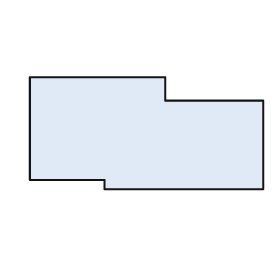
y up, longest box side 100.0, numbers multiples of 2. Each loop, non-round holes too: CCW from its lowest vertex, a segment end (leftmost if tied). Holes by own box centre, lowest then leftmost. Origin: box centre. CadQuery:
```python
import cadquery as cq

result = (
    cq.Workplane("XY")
    .moveTo(-18.0, -24.0)
    .lineTo(50.0, -24.0)
    .lineTo(50.0, 14.0)
    .lineTo(8.0, 14.0)
    .lineTo(8.0, 24.0)
    .lineTo(-50.0, 24.0)
    .lineTo(-50.0, -20.0)
    .lineTo(-18.0, -20.0)
    .close()
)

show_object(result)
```